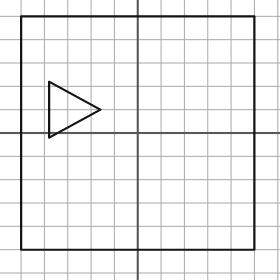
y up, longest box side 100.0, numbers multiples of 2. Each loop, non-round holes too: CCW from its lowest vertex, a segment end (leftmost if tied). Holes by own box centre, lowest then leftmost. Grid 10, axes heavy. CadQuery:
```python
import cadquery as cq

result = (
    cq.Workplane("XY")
    .moveTo(-50.0, -50.0)
    .lineTo(50.0, -50.0)
    .lineTo(50.0, 50.0)
    .lineTo(-50.0, 50.0)
    .close()
    .moveTo(-38.0, -2.0)
    .lineTo(-16.0, 10.0)
    .lineTo(-38.0, 22.0)
    .close()
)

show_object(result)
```